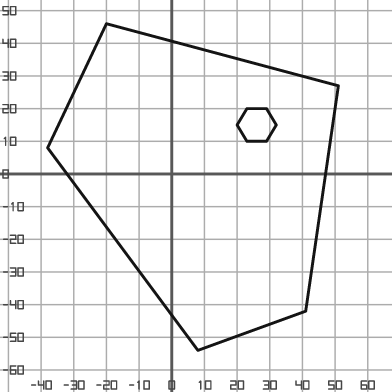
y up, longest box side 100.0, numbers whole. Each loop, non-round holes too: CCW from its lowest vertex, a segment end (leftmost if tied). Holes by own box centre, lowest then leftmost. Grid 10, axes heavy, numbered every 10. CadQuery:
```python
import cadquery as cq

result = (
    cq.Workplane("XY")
    .moveTo(8.0, -54.0)
    .lineTo(41.0, -42.0)
    .lineTo(51.0, 27.0)
    .lineTo(-20.0, 46.0)
    .lineTo(-38.0, 8.0)
    .close()
    .moveTo(23.0, 10.0)
    .lineTo(29.0, 10.0)
    .lineTo(32.0, 15.0)
    .lineTo(29.0, 20.0)
    .lineTo(23.0, 20.0)
    .lineTo(20.0, 15.0)
    .close()
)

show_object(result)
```